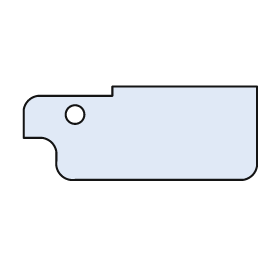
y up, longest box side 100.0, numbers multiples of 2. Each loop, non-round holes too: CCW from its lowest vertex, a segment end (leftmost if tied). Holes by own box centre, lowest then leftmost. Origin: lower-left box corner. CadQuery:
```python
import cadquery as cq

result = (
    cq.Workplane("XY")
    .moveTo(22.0, 0.0)
    .lineTo(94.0, 0.0)
    .threePointArc((98.0, 2.0), (100.0, 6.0))
    .lineTo(100.0, 40.0)
    .lineTo(38.0, 40.0)
    .lineTo(38.0, 36.0)
    .lineTo(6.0, 36.0)
    .threePointArc((2.0, 34.0), (0.0, 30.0))
    .lineTo(0.0, 18.0)
    .lineTo(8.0, 18.0)
    .threePointArc((12.0, 16.0), (14.0, 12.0))
    .lineTo(14.0, 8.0)
    .threePointArc((16.0, 2.0), (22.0, 0.0))
    .close()
    .moveTo(22.0, 28.0)
    .circle(4.0)
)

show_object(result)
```